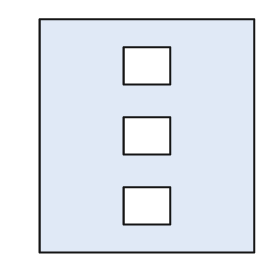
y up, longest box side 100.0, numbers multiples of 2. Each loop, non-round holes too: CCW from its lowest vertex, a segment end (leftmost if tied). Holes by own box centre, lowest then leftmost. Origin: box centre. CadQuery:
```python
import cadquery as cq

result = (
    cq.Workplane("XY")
    .moveTo(-46.0, -50.0)
    .lineTo(46.0, -50.0)
    .lineTo(46.0, 50.0)
    .lineTo(-46.0, 50.0)
    .close()
    .moveTo(-10.0, -38.0)
    .lineTo(10.0, -38.0)
    .lineTo(10.0, -22.0)
    .lineTo(-10.0, -22.0)
    .close()
    .moveTo(-10.0, -8.0)
    .lineTo(10.0, -8.0)
    .lineTo(10.0, 8.0)
    .lineTo(-10.0, 8.0)
    .close()
    .moveTo(-10.0, 22.0)
    .lineTo(10.0, 22.0)
    .lineTo(10.0, 38.0)
    .lineTo(-10.0, 38.0)
    .close()
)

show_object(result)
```